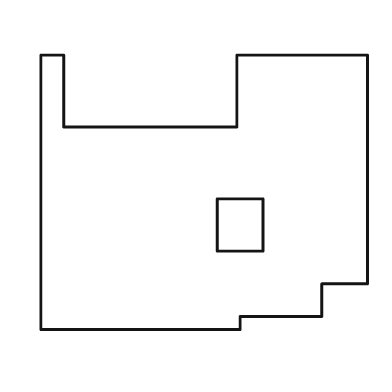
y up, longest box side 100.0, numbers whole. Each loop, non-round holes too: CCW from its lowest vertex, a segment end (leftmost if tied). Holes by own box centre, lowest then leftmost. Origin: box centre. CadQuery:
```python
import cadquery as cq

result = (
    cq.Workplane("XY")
    .moveTo(-50.0, -42.0)
    .lineTo(11.0, -42.0)
    .lineTo(11.0, -38.0)
    .lineTo(36.0, -38.0)
    .lineTo(36.0, -28.0)
    .lineTo(50.0, -28.0)
    .lineTo(50.0, 42.0)
    .lineTo(10.0, 42.0)
    .lineTo(10.0, 20.0)
    .lineTo(-43.0, 20.0)
    .lineTo(-43.0, 42.0)
    .lineTo(-50.0, 42.0)
    .close()
    .moveTo(4.0, -18.0)
    .lineTo(18.0, -18.0)
    .lineTo(18.0, -2.0)
    .lineTo(4.0, -2.0)
    .close()
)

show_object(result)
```